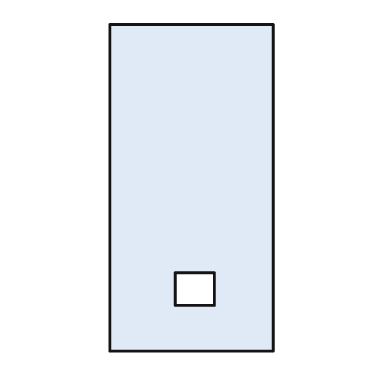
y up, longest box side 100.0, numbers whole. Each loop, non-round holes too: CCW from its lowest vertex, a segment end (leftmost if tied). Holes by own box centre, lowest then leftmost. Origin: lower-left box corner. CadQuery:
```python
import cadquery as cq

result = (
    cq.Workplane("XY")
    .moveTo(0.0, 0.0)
    .lineTo(50.0, 0.0)
    .lineTo(50.0, 100.0)
    .lineTo(0.0, 100.0)
    .close()
    .moveTo(20.0, 14.0)
    .lineTo(32.0, 14.0)
    .lineTo(32.0, 24.0)
    .lineTo(20.0, 24.0)
    .close()
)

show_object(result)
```